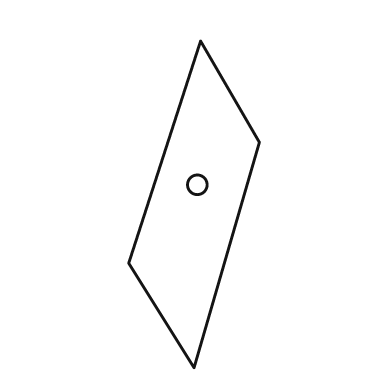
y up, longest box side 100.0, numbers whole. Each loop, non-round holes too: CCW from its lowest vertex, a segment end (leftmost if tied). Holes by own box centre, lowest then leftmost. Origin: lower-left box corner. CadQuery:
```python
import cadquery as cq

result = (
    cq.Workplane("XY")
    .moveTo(20.0, 0.0)
    .lineTo(40.0, 69.0)
    .lineTo(22.0, 100.0)
    .lineTo(0.0, 32.0)
    .close()
    .moveTo(21.0, 56.0)
    .circle(3.0)
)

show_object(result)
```